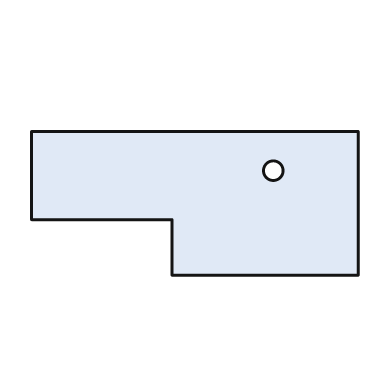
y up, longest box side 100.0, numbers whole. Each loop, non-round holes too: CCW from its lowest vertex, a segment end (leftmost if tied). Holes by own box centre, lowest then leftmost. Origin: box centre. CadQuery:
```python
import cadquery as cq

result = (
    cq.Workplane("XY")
    .moveTo(-7.0, -22.0)
    .lineTo(50.0, -22.0)
    .lineTo(50.0, 22.0)
    .lineTo(-50.0, 22.0)
    .lineTo(-50.0, -5.0)
    .lineTo(-7.0, -5.0)
    .close()
    .moveTo(24.0, 10.0)
    .circle(3.0)
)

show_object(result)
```